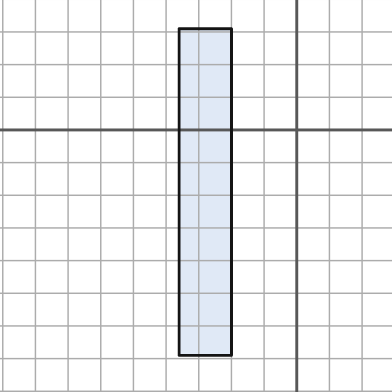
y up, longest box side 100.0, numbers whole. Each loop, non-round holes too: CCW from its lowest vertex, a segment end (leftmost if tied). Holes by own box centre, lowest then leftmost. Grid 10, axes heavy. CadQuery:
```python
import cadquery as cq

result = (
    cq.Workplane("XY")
    .moveTo(-36.0, -69.0)
    .lineTo(-20.0, -69.0)
    .lineTo(-20.0, 31.0)
    .lineTo(-36.0, 31.0)
    .close()
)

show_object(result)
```